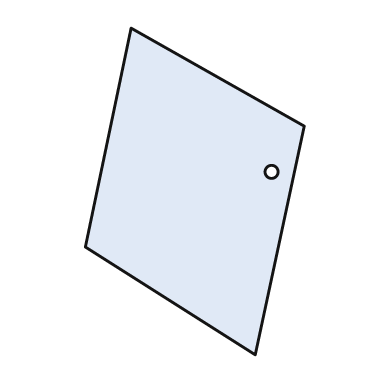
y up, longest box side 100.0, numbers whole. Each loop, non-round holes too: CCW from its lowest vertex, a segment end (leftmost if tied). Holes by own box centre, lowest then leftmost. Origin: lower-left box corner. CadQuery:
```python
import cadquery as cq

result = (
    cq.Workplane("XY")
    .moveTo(52.0, 0.0)
    .lineTo(67.0, 70.0)
    .lineTo(14.0, 100.0)
    .lineTo(0.0, 33.0)
    .close()
    .moveTo(57.0, 56.0)
    .circle(2.0)
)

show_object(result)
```